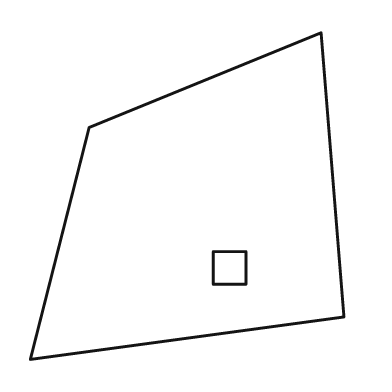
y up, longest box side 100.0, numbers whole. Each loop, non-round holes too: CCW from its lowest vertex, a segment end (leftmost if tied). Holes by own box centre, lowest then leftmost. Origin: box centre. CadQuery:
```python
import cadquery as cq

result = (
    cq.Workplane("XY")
    .moveTo(-48.0, -50.0)
    .lineTo(48.0, -37.0)
    .lineTo(41.0, 50.0)
    .lineTo(-30.0, 21.0)
    .close()
    .moveTo(8.0, -27.0)
    .lineTo(18.0, -27.0)
    .lineTo(18.0, -17.0)
    .lineTo(8.0, -17.0)
    .close()
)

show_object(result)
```